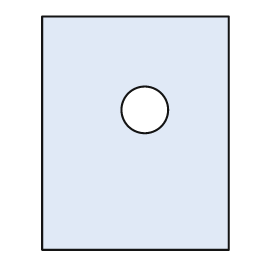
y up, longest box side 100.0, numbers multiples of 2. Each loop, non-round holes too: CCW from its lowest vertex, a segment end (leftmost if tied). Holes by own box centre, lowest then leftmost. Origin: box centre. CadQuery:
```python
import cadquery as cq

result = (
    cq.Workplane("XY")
    .moveTo(-40.0, -50.0)
    .lineTo(40.0, -50.0)
    .lineTo(40.0, 50.0)
    .lineTo(-40.0, 50.0)
    .close()
    .moveTo(4.0, 10.0)
    .circle(10.0)
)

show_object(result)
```